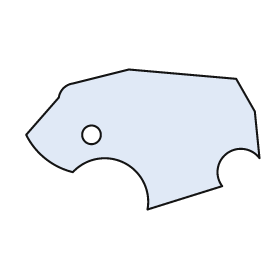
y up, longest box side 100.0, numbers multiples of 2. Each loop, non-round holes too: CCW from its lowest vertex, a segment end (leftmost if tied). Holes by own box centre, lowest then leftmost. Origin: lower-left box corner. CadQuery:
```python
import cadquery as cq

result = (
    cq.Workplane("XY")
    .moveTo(52.0, 0.0)
    .lineTo(84.0, 10.0)
    .threePointArc((86.0, 24.0), (100.0, 22.0))
    .lineTo(98.0, 42.0)
    .lineTo(90.0, 56.0)
    .lineTo(44.0, 60.0)
    .lineTo(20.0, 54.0)
    .threePointArc((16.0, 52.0), (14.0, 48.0))
    .lineTo(0.0, 32.0)
    .threePointArc((8.0, 22.0), (20.0, 16.0))
    .threePointArc((42.0, 20.0), (52.0, 0.0))
    .close()
    .moveTo(28.0, 32.0)
    .circle(4.0)
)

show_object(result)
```